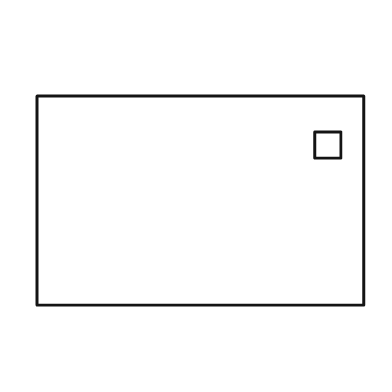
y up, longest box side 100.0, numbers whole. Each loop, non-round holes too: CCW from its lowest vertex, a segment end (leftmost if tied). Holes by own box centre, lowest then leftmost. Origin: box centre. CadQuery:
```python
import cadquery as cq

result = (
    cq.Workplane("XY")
    .moveTo(-50.0, -32.0)
    .lineTo(50.0, -32.0)
    .lineTo(50.0, 32.0)
    .lineTo(-50.0, 32.0)
    .close()
    .moveTo(35.0, 13.0)
    .lineTo(43.0, 13.0)
    .lineTo(43.0, 21.0)
    .lineTo(35.0, 21.0)
    .close()
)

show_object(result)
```